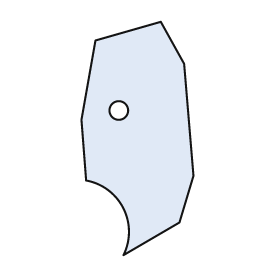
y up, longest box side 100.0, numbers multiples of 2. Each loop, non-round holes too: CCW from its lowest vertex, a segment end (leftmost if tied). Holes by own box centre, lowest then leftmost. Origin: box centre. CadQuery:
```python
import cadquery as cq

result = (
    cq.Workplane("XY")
    .moveTo(-6.0, -50.0)
    .lineTo(18.0, -36.0)
    .lineTo(24.0, -16.0)
    .lineTo(20.0, 32.0)
    .lineTo(10.0, 50.0)
    .lineTo(-18.0, 42.0)
    .lineTo(-24.0, 8.0)
    .lineTo(-22.0, -18.0)
    .threePointArc((-6.0, -30.0), (-6.0, -50.0))
    .close()
    .moveTo(-8.0, 12.0)
    .circle(4.0)
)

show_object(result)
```